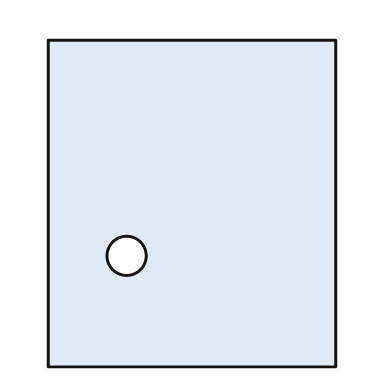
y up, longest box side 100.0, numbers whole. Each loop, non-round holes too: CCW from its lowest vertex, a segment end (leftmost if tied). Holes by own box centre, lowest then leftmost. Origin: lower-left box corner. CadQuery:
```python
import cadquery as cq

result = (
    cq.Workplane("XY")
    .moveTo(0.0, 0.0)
    .lineTo(88.0, 0.0)
    .lineTo(88.0, 100.0)
    .lineTo(0.0, 100.0)
    .close()
    .moveTo(24.0, 34.0)
    .circle(6.0)
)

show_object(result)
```